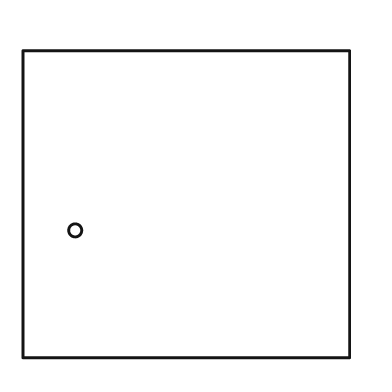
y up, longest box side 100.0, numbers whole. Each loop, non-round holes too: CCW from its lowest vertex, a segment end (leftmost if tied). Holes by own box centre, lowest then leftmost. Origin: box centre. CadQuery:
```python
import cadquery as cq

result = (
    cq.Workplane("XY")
    .moveTo(-50.0, -47.0)
    .lineTo(50.0, -47.0)
    .lineTo(50.0, 47.0)
    .lineTo(-50.0, 47.0)
    .close()
    .moveTo(-34.0, -8.0)
    .circle(2.0)
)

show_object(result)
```